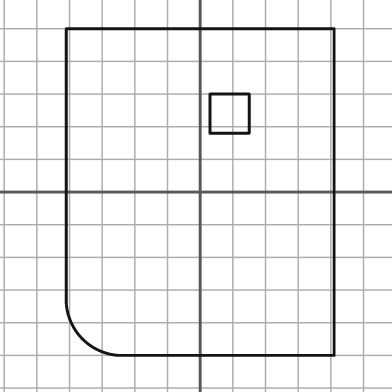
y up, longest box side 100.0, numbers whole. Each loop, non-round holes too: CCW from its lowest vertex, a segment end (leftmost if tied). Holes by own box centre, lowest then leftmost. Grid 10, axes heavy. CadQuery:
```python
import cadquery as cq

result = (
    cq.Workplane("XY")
    .moveTo(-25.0, -50.0)
    .lineTo(41.0, -50.0)
    .lineTo(41.0, 50.0)
    .lineTo(-41.0, 50.0)
    .lineTo(-41.0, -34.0)
    .threePointArc((-36.0, -45.0), (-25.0, -50.0))
    .close()
    .moveTo(3.0, 18.0)
    .lineTo(15.0, 18.0)
    .lineTo(15.0, 30.0)
    .lineTo(3.0, 30.0)
    .close()
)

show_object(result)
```